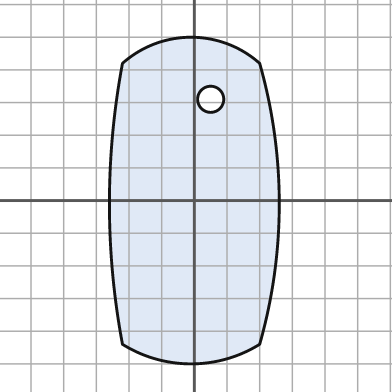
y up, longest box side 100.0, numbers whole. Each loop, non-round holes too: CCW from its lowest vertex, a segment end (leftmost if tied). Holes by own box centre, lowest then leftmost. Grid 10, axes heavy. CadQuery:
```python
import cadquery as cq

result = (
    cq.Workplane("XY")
    .moveTo(-22.0, -44.0)
    .threePointArc((-1.0, -50.0), (20.0, -44.0))
    .threePointArc((26.0, -1.0), (20.0, 42.0))
    .threePointArc((-1.0, 50.0), (-22.0, 42.0))
    .threePointArc((-26.0, -1.0), (-22.0, -44.0))
    .close()
    .moveTo(5.0, 31.0)
    .circle(4.0)
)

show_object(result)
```